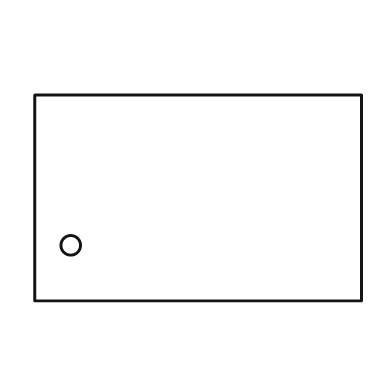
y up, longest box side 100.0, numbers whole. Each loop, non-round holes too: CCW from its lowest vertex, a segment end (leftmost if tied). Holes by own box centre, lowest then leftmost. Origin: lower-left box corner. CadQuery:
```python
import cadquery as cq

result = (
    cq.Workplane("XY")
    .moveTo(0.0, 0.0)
    .lineTo(100.0, 0.0)
    .lineTo(100.0, 63.0)
    .lineTo(0.0, 63.0)
    .close()
    .moveTo(11.0, 17.0)
    .circle(3.0)
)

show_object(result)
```